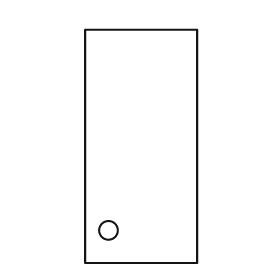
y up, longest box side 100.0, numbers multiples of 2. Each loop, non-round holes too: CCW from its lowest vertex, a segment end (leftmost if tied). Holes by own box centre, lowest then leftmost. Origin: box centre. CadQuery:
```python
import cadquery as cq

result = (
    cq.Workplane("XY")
    .moveTo(-24.0, -50.0)
    .lineTo(24.0, -50.0)
    .lineTo(24.0, 50.0)
    .lineTo(-24.0, 50.0)
    .close()
    .moveTo(-14.0, -36.0)
    .circle(4.0)
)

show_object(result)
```